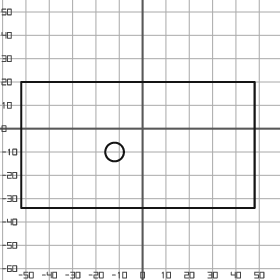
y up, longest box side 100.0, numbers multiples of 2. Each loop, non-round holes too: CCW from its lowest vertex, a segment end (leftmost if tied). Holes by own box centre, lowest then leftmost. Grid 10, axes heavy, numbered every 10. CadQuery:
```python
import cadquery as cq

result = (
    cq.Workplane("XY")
    .moveTo(-52.0, -34.0)
    .lineTo(48.0, -34.0)
    .lineTo(48.0, 20.0)
    .lineTo(-52.0, 20.0)
    .close()
    .moveTo(-12.0, -10.0)
    .circle(4.0)
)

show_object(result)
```